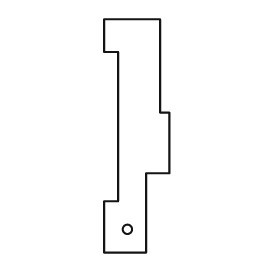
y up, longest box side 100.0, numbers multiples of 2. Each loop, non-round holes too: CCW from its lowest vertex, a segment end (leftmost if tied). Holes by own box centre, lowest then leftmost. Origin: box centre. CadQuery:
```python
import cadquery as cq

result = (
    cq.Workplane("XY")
    .moveTo(-14.0, -50.0)
    .lineTo(4.0, -50.0)
    .lineTo(4.0, -16.0)
    .lineTo(14.0, -16.0)
    .lineTo(14.0, 10.0)
    .lineTo(10.0, 10.0)
    .lineTo(10.0, 50.0)
    .lineTo(-14.0, 50.0)
    .lineTo(-14.0, 36.0)
    .lineTo(-8.0, 36.0)
    .lineTo(-8.0, -28.0)
    .lineTo(-14.0, -28.0)
    .close()
    .moveTo(-4.0, -40.0)
    .circle(2.0)
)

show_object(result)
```